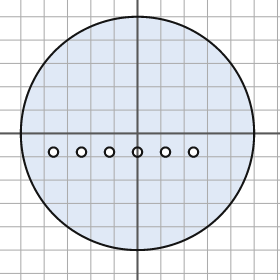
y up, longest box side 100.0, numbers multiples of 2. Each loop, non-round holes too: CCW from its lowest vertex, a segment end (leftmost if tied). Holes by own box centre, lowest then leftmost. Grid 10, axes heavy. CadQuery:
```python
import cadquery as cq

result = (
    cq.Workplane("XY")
    .moveTo(0.0, 0.0)
    .circle(50.0)
    .moveTo(-36.0, -8.0)
    .circle(2.0)
    .moveTo(-24.0, -8.0)
    .circle(2.0)
    .moveTo(-12.0, -8.0)
    .circle(2.0)
    .moveTo(0.0, -8.0)
    .circle(2.0)
    .moveTo(12.0, -8.0)
    .circle(2.0)
    .moveTo(24.0, -8.0)
    .circle(2.0)
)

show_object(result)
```